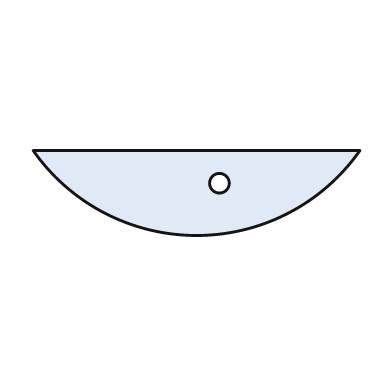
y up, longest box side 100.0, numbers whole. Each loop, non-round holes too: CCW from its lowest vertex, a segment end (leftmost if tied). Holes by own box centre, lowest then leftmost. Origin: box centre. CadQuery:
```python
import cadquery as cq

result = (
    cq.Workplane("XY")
    .moveTo(-50.0, 13.0)
    .threePointArc((0.0, -13.0), (50.0, 13.0))
    .close()
    .moveTo(7.0, 3.0)
    .circle(3.0)
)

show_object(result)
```